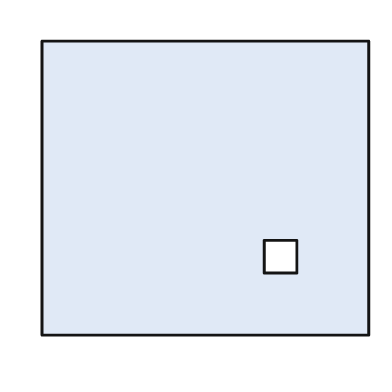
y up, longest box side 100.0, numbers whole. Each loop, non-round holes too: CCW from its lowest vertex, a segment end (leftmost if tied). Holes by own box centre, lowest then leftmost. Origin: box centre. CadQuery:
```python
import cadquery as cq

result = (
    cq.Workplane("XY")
    .moveTo(-50.0, -45.0)
    .lineTo(50.0, -45.0)
    .lineTo(50.0, 45.0)
    .lineTo(-50.0, 45.0)
    .close()
    .moveTo(18.0, -26.0)
    .lineTo(28.0, -26.0)
    .lineTo(28.0, -16.0)
    .lineTo(18.0, -16.0)
    .close()
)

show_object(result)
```